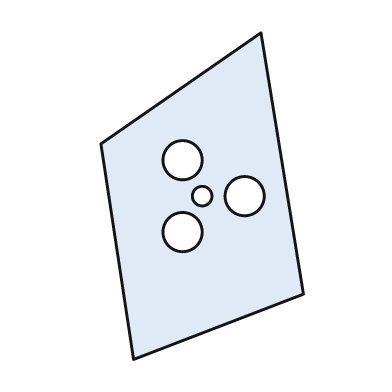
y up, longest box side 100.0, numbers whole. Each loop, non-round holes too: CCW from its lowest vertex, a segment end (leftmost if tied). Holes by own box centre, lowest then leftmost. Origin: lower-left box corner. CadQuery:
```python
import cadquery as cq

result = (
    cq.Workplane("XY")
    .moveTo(10.0, 0.0)
    .lineTo(62.0, 20.0)
    .lineTo(49.0, 100.0)
    .lineTo(0.0, 66.0)
    .close()
    .moveTo(25.0, 39.0)
    .circle(6.0)
    .moveTo(31.0, 50.0)
    .circle(3.0)
    .moveTo(44.0, 50.0)
    .circle(6.0)
    .moveTo(25.0, 61.0)
    .circle(6.0)
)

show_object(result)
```